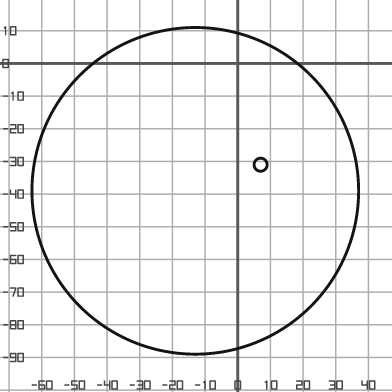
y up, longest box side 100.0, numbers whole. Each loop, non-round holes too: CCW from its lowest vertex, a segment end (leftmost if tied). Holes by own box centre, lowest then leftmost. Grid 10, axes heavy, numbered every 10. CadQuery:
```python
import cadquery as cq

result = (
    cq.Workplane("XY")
    .moveTo(-13.0, -39.0)
    .circle(50.0)
    .moveTo(7.0, -31.0)
    .circle(2.0)
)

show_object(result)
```